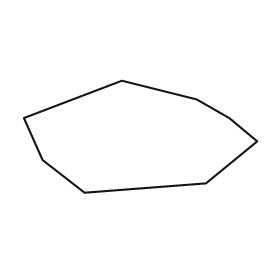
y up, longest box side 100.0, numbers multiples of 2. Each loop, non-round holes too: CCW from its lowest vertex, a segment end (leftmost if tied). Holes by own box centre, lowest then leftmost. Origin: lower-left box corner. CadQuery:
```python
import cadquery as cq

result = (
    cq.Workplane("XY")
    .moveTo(26.0, 0.0)
    .lineTo(78.0, 4.0)
    .lineTo(100.0, 22.0)
    .lineTo(88.0, 32.0)
    .lineTo(74.0, 40.0)
    .lineTo(42.0, 48.0)
    .lineTo(0.0, 32.0)
    .lineTo(8.0, 14.0)
    .close()
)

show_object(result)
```